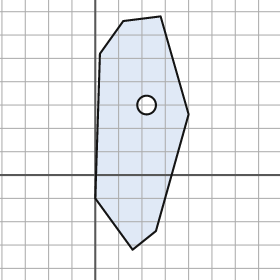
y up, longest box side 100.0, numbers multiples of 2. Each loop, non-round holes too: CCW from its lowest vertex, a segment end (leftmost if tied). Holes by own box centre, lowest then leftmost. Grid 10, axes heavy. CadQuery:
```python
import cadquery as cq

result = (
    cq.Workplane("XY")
    .moveTo(16.0, -32.0)
    .lineTo(26.0, -24.0)
    .lineTo(40.0, 26.0)
    .lineTo(28.0, 68.0)
    .lineTo(12.0, 66.0)
    .lineTo(2.0, 52.0)
    .lineTo(0.0, -10.0)
    .close()
    .moveTo(22.0, 30.0)
    .circle(4.0)
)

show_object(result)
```